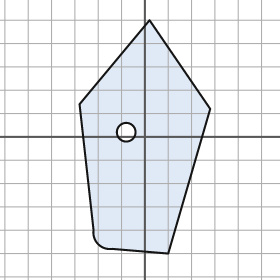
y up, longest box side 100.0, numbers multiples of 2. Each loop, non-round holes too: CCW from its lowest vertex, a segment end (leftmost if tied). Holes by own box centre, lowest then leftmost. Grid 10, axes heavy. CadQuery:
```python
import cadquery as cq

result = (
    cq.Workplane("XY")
    .moveTo(10.0, -50.0)
    .lineTo(28.0, 12.0)
    .lineTo(2.0, 50.0)
    .lineTo(-28.0, 14.0)
    .lineTo(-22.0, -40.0)
    .threePointArc((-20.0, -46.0), (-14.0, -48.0))
    .close()
    .moveTo(-8.0, 2.0)
    .circle(4.0)
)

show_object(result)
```